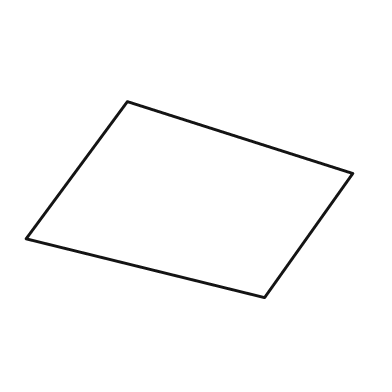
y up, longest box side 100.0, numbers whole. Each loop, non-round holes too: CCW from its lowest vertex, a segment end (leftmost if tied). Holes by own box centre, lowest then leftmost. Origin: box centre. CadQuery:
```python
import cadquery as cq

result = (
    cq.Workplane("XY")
    .moveTo(23.0, -30.0)
    .lineTo(50.0, 8.0)
    .lineTo(-19.0, 30.0)
    .lineTo(-50.0, -12.0)
    .close()
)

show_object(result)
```